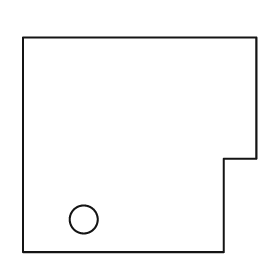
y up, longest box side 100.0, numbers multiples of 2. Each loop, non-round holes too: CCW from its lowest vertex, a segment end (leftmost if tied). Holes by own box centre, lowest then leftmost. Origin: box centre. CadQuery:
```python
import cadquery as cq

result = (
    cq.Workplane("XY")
    .moveTo(-50.0, -46.0)
    .lineTo(36.0, -46.0)
    .lineTo(36.0, -6.0)
    .lineTo(50.0, -6.0)
    .lineTo(50.0, 46.0)
    .lineTo(-50.0, 46.0)
    .close()
    .moveTo(-24.0, -32.0)
    .circle(6.0)
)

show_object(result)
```